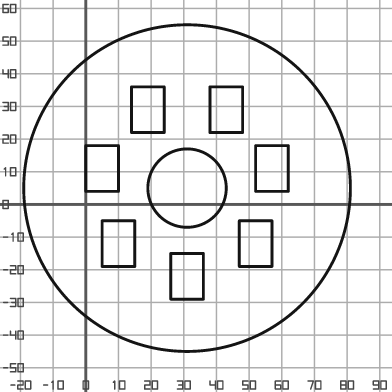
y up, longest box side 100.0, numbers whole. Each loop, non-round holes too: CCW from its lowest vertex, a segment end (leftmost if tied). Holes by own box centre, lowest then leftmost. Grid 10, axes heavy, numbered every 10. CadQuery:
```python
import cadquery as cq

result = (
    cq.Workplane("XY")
    .moveTo(31.0, 5.0)
    .circle(50.0)
    .moveTo(26.0, -29.0)
    .lineTo(36.0, -29.0)
    .lineTo(36.0, -15.0)
    .lineTo(26.0, -15.0)
    .close()
    .moveTo(5.0, -19.0)
    .lineTo(15.0, -19.0)
    .lineTo(15.0, -5.0)
    .lineTo(5.0, -5.0)
    .close()
    .moveTo(47.0, -19.0)
    .lineTo(57.0, -19.0)
    .lineTo(57.0, -5.0)
    .lineTo(47.0, -5.0)
    .close()
    .moveTo(31.0, 5.0)
    .circle(12.0)
    .moveTo(0.0, 4.0)
    .lineTo(10.0, 4.0)
    .lineTo(10.0, 18.0)
    .lineTo(0.0, 18.0)
    .close()
    .moveTo(52.0, 4.0)
    .lineTo(62.0, 4.0)
    .lineTo(62.0, 18.0)
    .lineTo(52.0, 18.0)
    .close()
    .moveTo(14.0, 22.0)
    .lineTo(24.0, 22.0)
    .lineTo(24.0, 36.0)
    .lineTo(14.0, 36.0)
    .close()
    .moveTo(38.0, 22.0)
    .lineTo(48.0, 22.0)
    .lineTo(48.0, 36.0)
    .lineTo(38.0, 36.0)
    .close()
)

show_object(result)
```